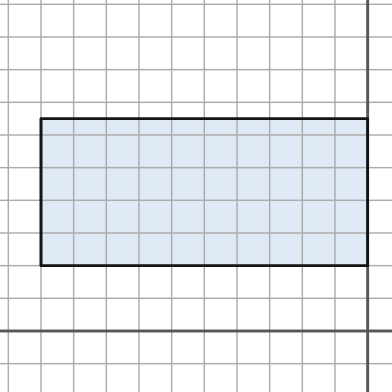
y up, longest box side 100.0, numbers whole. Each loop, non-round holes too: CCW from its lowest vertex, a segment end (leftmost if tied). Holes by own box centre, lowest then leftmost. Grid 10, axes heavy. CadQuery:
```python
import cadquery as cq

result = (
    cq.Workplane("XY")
    .moveTo(-100.0, 20.0)
    .lineTo(0.0, 20.0)
    .lineTo(0.0, 65.0)
    .lineTo(-100.0, 65.0)
    .close()
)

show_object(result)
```